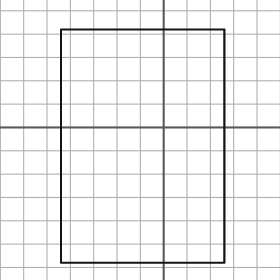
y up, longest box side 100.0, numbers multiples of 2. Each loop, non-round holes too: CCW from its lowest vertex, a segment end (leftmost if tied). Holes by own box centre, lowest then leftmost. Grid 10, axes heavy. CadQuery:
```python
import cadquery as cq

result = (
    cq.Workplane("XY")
    .moveTo(-44.0, -58.0)
    .lineTo(26.0, -58.0)
    .lineTo(26.0, 42.0)
    .lineTo(-44.0, 42.0)
    .close()
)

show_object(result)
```